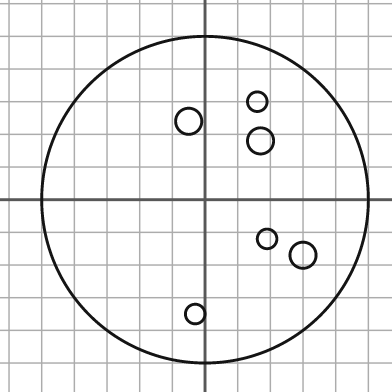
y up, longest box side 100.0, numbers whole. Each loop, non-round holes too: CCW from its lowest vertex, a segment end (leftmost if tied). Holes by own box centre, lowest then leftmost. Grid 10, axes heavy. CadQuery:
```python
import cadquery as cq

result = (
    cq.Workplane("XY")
    .moveTo(0.0, 0.0)
    .circle(50.0)
    .moveTo(-3.0, -35.0)
    .circle(3.0)
    .moveTo(30.0, -17.0)
    .circle(4.0)
    .moveTo(19.0, -12.0)
    .circle(3.0)
    .moveTo(17.0, 18.0)
    .circle(4.0)
    .moveTo(-5.0, 24.0)
    .circle(4.0)
    .moveTo(16.0, 30.0)
    .circle(3.0)
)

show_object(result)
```